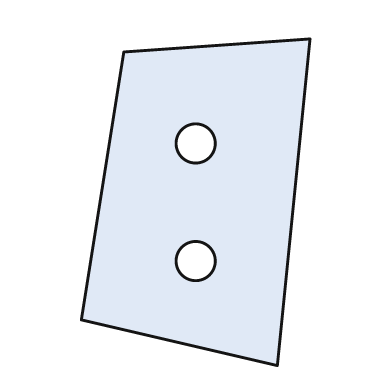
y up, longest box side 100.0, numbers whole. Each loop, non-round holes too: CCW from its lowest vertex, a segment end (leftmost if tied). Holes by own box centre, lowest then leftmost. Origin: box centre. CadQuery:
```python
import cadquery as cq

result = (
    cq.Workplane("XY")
    .moveTo(25.0, -50.0)
    .lineTo(35.0, 50.0)
    .lineTo(-22.0, 46.0)
    .lineTo(-35.0, -36.0)
    .close()
    .moveTo(0.0, -18.0)
    .circle(6.0)
    .moveTo(0.0, 18.0)
    .circle(6.0)
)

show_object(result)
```